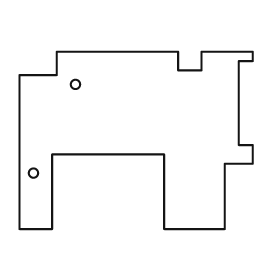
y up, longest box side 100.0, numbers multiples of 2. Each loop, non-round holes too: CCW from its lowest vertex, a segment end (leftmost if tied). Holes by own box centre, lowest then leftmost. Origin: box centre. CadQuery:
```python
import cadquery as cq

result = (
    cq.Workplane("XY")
    .moveTo(-50.0, -38.0)
    .lineTo(-36.0, -38.0)
    .lineTo(-36.0, -6.0)
    .lineTo(12.0, -6.0)
    .lineTo(12.0, -38.0)
    .lineTo(38.0, -38.0)
    .lineTo(38.0, -10.0)
    .lineTo(50.0, -10.0)
    .lineTo(50.0, -2.0)
    .lineTo(44.0, -2.0)
    .lineTo(44.0, 34.0)
    .lineTo(50.0, 34.0)
    .lineTo(50.0, 38.0)
    .lineTo(28.0, 38.0)
    .lineTo(28.0, 30.0)
    .lineTo(18.0, 30.0)
    .lineTo(18.0, 38.0)
    .lineTo(-34.0, 38.0)
    .lineTo(-34.0, 28.0)
    .lineTo(-50.0, 28.0)
    .close()
    .moveTo(-44.0, -14.0)
    .circle(2.0)
    .moveTo(-26.0, 24.0)
    .circle(2.0)
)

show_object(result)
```